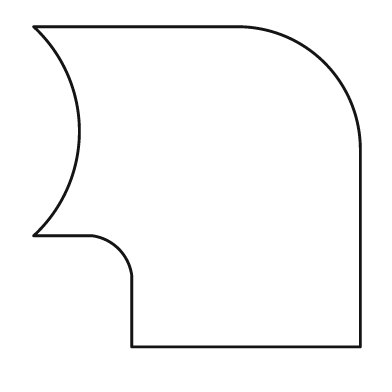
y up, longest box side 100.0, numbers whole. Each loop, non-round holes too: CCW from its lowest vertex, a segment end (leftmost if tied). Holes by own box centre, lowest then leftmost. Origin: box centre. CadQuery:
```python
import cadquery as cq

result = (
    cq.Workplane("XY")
    .moveTo(-20.0, -49.0)
    .lineTo(50.0, -49.0)
    .lineTo(50.0, 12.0)
    .threePointArc((39.0, 38.0), (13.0, 49.0))
    .lineTo(-50.0, 49.0)
    .threePointArc((-36.0, 17.0), (-50.0, -15.0))
    .lineTo(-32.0, -15.0)
    .threePointArc((-24.0, -19.0), (-20.0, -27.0))
    .close()
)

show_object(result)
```